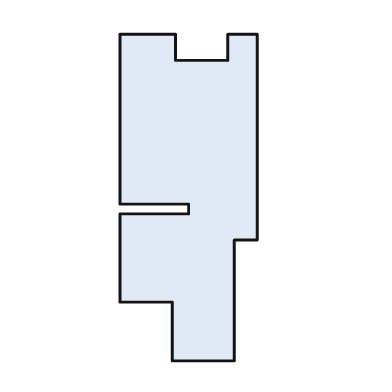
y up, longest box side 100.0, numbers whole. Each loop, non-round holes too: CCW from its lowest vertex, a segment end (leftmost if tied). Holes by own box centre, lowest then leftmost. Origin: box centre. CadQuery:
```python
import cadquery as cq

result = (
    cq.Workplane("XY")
    .moveTo(-5.0, -50.0)
    .lineTo(14.0, -50.0)
    .lineTo(14.0, -13.0)
    .lineTo(21.0, -13.0)
    .lineTo(21.0, 50.0)
    .lineTo(12.0, 50.0)
    .lineTo(12.0, 42.0)
    .lineTo(-4.0, 42.0)
    .lineTo(-4.0, 50.0)
    .lineTo(-21.0, 50.0)
    .lineTo(-21.0, -2.0)
    .lineTo(0.0, -2.0)
    .lineTo(0.0, -5.0)
    .lineTo(-21.0, -5.0)
    .lineTo(-21.0, -32.0)
    .lineTo(-5.0, -32.0)
    .close()
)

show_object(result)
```